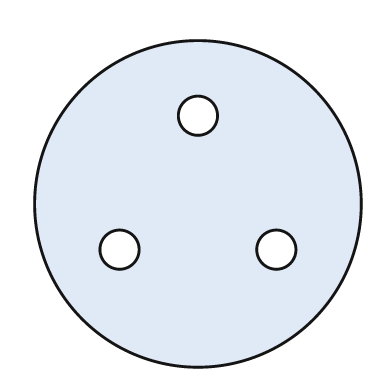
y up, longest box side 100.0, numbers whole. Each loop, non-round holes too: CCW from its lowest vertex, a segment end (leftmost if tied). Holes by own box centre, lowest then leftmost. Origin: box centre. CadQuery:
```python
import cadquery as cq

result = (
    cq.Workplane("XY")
    .moveTo(0.0, 0.0)
    .circle(50.0)
    .moveTo(-24.0, -14.0)
    .circle(6.0)
    .moveTo(24.0, -14.0)
    .circle(6.0)
    .moveTo(0.0, 27.0)
    .circle(6.0)
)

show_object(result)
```